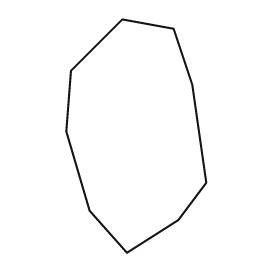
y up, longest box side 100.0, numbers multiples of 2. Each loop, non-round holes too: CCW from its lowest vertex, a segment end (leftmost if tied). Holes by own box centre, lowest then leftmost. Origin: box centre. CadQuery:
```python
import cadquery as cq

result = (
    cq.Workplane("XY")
    .moveTo(-4.0, -50.0)
    .lineTo(18.0, -36.0)
    .lineTo(30.0, -20.0)
    .lineTo(24.0, 22.0)
    .lineTo(16.0, 46.0)
    .lineTo(-6.0, 50.0)
    .lineTo(-28.0, 28.0)
    .lineTo(-30.0, 2.0)
    .lineTo(-20.0, -32.0)
    .close()
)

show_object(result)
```